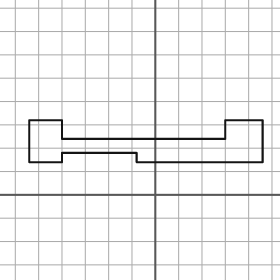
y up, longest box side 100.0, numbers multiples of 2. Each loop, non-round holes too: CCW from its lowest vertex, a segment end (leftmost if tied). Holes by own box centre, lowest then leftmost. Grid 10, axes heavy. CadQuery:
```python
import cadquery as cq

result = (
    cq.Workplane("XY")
    .moveTo(-54.0, 14.0)
    .lineTo(-40.0, 14.0)
    .lineTo(-40.0, 18.0)
    .lineTo(-8.0, 18.0)
    .lineTo(-8.0, 14.0)
    .lineTo(46.0, 14.0)
    .lineTo(46.0, 32.0)
    .lineTo(30.0, 32.0)
    .lineTo(30.0, 24.0)
    .lineTo(-40.0, 24.0)
    .lineTo(-40.0, 32.0)
    .lineTo(-54.0, 32.0)
    .close()
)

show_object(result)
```